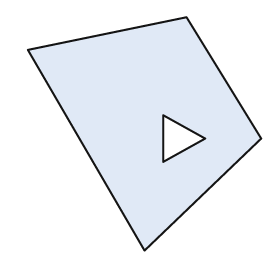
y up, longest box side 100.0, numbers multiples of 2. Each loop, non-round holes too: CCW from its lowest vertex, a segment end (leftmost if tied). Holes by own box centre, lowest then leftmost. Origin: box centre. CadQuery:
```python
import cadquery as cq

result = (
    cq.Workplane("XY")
    .moveTo(0.0, -50.0)
    .lineTo(50.0, -2.0)
    .lineTo(18.0, 50.0)
    .lineTo(-50.0, 36.0)
    .close()
    .moveTo(8.0, -12.0)
    .lineTo(26.0, -2.0)
    .lineTo(8.0, 8.0)
    .close()
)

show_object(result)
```